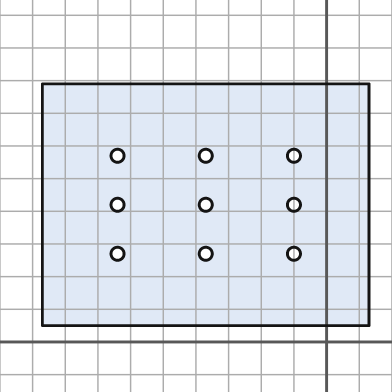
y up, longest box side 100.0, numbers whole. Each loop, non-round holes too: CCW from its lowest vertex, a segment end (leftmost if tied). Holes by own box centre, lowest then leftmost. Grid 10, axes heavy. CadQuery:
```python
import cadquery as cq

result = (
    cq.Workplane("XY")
    .moveTo(-87.0, 5.0)
    .lineTo(13.0, 5.0)
    .lineTo(13.0, 79.0)
    .lineTo(-87.0, 79.0)
    .close()
    .moveTo(-64.0, 27.0)
    .circle(2.0)
    .moveTo(-37.0, 27.0)
    .circle(2.0)
    .moveTo(-10.0, 27.0)
    .circle(2.0)
    .moveTo(-64.0, 42.0)
    .circle(2.0)
    .moveTo(-37.0, 42.0)
    .circle(2.0)
    .moveTo(-10.0, 42.0)
    .circle(2.0)
    .moveTo(-64.0, 57.0)
    .circle(2.0)
    .moveTo(-37.0, 57.0)
    .circle(2.0)
    .moveTo(-10.0, 57.0)
    .circle(2.0)
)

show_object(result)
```